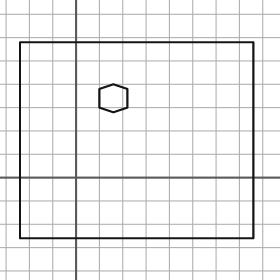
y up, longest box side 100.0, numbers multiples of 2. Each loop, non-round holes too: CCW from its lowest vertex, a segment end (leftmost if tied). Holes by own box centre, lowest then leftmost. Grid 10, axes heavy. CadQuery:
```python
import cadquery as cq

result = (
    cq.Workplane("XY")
    .moveTo(-24.0, -26.0)
    .lineTo(76.0, -26.0)
    .lineTo(76.0, 58.0)
    .lineTo(-24.0, 58.0)
    .close()
    .moveTo(16.0, 28.0)
    .lineTo(22.0, 30.0)
    .lineTo(22.0, 38.0)
    .lineTo(16.0, 40.0)
    .lineTo(10.0, 38.0)
    .lineTo(10.0, 30.0)
    .close()
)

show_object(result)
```